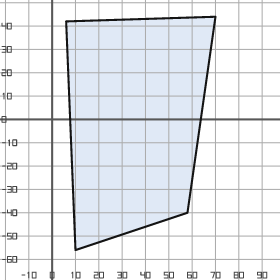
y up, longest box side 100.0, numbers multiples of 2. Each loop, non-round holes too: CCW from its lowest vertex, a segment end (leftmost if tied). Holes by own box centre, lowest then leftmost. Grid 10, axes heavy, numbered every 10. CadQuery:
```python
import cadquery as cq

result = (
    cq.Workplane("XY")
    .moveTo(10.0, -56.0)
    .lineTo(58.0, -40.0)
    .lineTo(70.0, 44.0)
    .lineTo(6.0, 42.0)
    .close()
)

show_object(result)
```